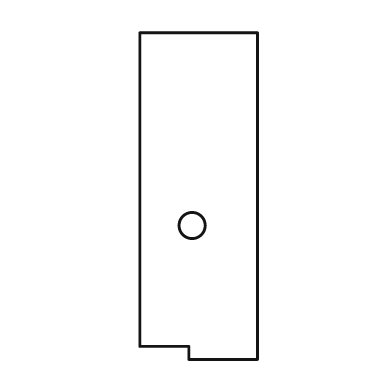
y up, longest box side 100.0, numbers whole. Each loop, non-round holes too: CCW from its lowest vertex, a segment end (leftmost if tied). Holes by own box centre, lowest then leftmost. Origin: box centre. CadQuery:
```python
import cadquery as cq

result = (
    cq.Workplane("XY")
    .moveTo(-3.0, -50.0)
    .lineTo(18.0, -50.0)
    .lineTo(18.0, 50.0)
    .lineTo(-18.0, 50.0)
    .lineTo(-18.0, -46.0)
    .lineTo(-3.0, -46.0)
    .close()
    .moveTo(-2.0, -9.0)
    .circle(4.0)
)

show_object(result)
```